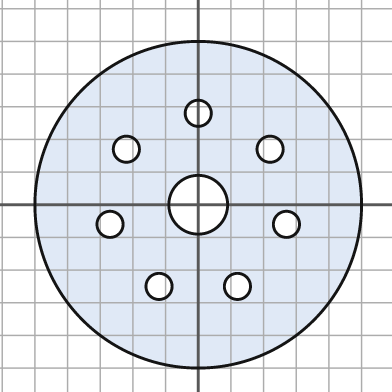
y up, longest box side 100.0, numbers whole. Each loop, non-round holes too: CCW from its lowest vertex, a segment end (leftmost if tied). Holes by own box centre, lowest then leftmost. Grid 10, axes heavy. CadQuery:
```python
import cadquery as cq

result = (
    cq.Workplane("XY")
    .moveTo(0.0, 0.0)
    .circle(50.0)
    .moveTo(-12.0, -25.0)
    .circle(4.0)
    .moveTo(12.0, -25.0)
    .circle(4.0)
    .moveTo(-27.0, -6.0)
    .circle(4.0)
    .moveTo(27.0, -6.0)
    .circle(4.0)
    .moveTo(0.0, 0.0)
    .circle(9.0)
    .moveTo(-22.0, 17.0)
    .circle(4.0)
    .moveTo(22.0, 17.0)
    .circle(4.0)
    .moveTo(0.0, 28.0)
    .circle(4.0)
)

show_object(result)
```